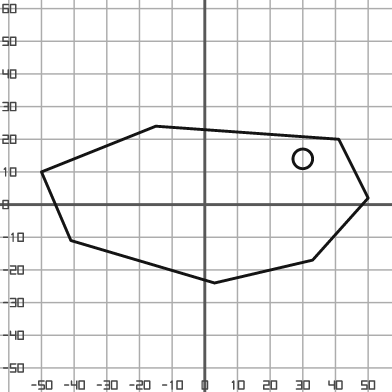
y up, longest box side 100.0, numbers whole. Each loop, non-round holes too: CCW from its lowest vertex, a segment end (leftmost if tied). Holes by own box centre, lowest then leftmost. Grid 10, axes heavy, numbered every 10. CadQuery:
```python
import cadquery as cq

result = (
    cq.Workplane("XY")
    .moveTo(3.0, -24.0)
    .lineTo(33.0, -17.0)
    .lineTo(50.0, 2.0)
    .lineTo(41.0, 20.0)
    .lineTo(-15.0, 24.0)
    .lineTo(-50.0, 10.0)
    .lineTo(-41.0, -11.0)
    .close()
    .moveTo(30.0, 14.0)
    .circle(3.0)
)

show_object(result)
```